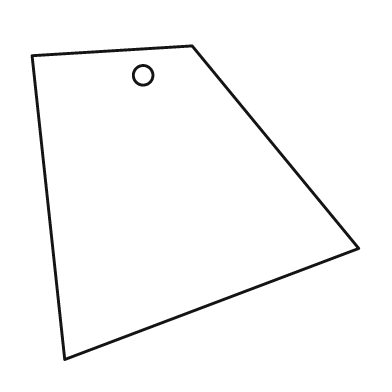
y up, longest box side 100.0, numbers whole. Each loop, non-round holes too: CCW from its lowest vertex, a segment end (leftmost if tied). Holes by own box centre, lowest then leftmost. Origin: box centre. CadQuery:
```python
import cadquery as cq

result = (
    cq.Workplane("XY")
    .moveTo(-40.0, -48.0)
    .lineTo(50.0, -14.0)
    .lineTo(-1.0, 48.0)
    .lineTo(-50.0, 45.0)
    .close()
    .moveTo(-16.0, 39.0)
    .circle(3.0)
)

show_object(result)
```